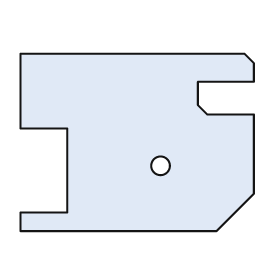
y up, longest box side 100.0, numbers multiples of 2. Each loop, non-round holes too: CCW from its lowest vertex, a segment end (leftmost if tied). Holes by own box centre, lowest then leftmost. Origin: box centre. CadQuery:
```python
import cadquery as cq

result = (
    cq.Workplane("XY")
    .moveTo(-50.0, -38.0)
    .lineTo(34.0, -38.0)
    .lineTo(50.0, -22.0)
    .lineTo(50.0, 12.0)
    .lineTo(30.0, 12.0)
    .lineTo(26.0, 16.0)
    .lineTo(26.0, 26.0)
    .lineTo(50.0, 26.0)
    .lineTo(50.0, 34.0)
    .lineTo(46.0, 38.0)
    .lineTo(-50.0, 38.0)
    .lineTo(-50.0, 6.0)
    .lineTo(-30.0, 6.0)
    .lineTo(-30.0, -30.0)
    .lineTo(-50.0, -30.0)
    .close()
    .moveTo(10.0, -10.0)
    .circle(4.0)
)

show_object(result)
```